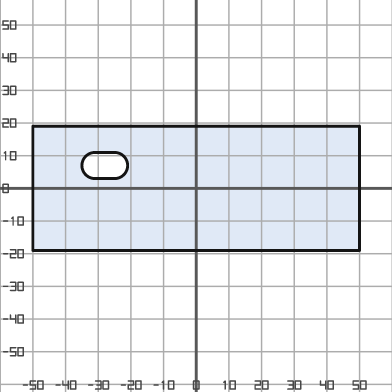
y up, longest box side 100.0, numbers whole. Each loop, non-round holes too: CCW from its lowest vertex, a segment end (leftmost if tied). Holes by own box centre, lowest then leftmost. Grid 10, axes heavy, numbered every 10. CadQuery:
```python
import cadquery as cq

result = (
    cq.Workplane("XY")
    .moveTo(-50.0, -19.0)
    .lineTo(50.0, -19.0)
    .lineTo(50.0, 19.0)
    .lineTo(-50.0, 19.0)
    .close()
    .moveTo(-31.0, 3.0)
    .lineTo(-25.0, 3.0)
    .threePointArc((-21.0, 7.0), (-25.0, 11.0))
    .lineTo(-31.0, 11.0)
    .threePointArc((-35.0, 7.0), (-31.0, 3.0))
    .close()
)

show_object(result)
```